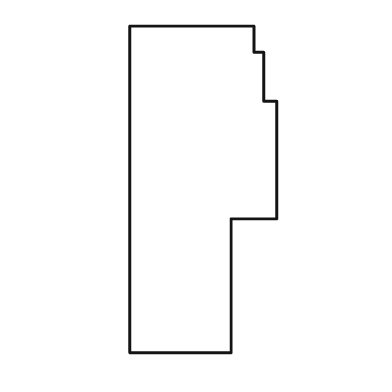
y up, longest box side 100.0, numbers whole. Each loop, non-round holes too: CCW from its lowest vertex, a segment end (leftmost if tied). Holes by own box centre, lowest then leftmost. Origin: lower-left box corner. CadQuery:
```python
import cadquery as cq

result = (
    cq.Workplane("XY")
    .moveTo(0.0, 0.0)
    .lineTo(31.0, 0.0)
    .lineTo(31.0, 41.0)
    .lineTo(45.0, 41.0)
    .lineTo(45.0, 77.0)
    .lineTo(41.0, 77.0)
    .lineTo(41.0, 92.0)
    .lineTo(38.0, 92.0)
    .lineTo(38.0, 100.0)
    .lineTo(0.0, 100.0)
    .close()
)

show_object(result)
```